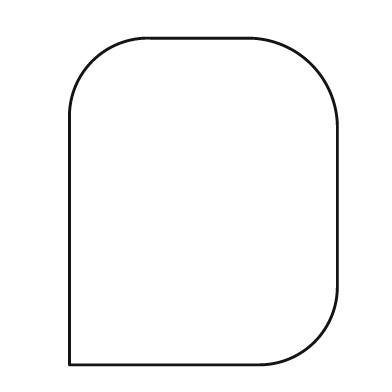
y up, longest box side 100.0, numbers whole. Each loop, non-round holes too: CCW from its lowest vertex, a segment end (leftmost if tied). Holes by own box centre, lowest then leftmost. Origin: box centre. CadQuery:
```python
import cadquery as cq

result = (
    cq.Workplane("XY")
    .moveTo(-41.0, -50.0)
    .lineTo(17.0, -50.0)
    .threePointArc((34.0, -43.0), (41.0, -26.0))
    .lineTo(41.0, 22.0)
    .threePointArc((33.0, 42.0), (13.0, 50.0))
    .lineTo(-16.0, 50.0)
    .threePointArc((-34.0, 43.0), (-41.0, 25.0))
    .close()
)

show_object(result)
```